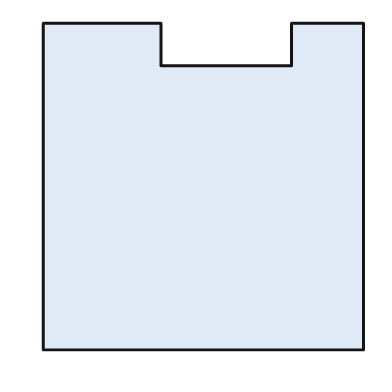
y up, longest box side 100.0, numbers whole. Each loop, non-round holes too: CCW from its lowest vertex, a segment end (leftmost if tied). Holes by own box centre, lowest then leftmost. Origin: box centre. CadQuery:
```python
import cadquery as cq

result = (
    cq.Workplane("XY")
    .moveTo(-49.0, -50.0)
    .lineTo(49.0, -50.0)
    .lineTo(49.0, 50.0)
    .lineTo(27.0, 50.0)
    .lineTo(27.0, 37.0)
    .lineTo(-13.0, 37.0)
    .lineTo(-13.0, 50.0)
    .lineTo(-49.0, 50.0)
    .close()
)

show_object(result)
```